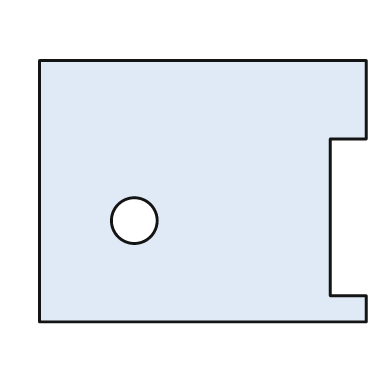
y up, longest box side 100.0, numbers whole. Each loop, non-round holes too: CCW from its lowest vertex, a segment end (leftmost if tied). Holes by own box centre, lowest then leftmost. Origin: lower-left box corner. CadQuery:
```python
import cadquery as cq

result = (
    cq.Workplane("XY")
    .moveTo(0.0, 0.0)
    .lineTo(100.0, 0.0)
    .lineTo(100.0, 8.0)
    .lineTo(89.0, 8.0)
    .lineTo(89.0, 56.0)
    .lineTo(100.0, 56.0)
    .lineTo(100.0, 80.0)
    .lineTo(0.0, 80.0)
    .close()
    .moveTo(29.0, 31.0)
    .circle(7.0)
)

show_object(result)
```